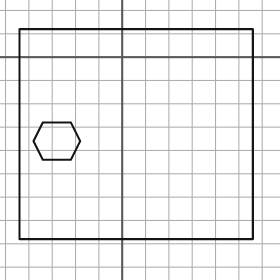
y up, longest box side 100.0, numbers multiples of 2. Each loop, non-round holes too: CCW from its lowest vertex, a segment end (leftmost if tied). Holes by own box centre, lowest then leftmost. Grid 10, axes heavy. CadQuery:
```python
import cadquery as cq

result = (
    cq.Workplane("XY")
    .moveTo(-44.0, -78.0)
    .lineTo(56.0, -78.0)
    .lineTo(56.0, 12.0)
    .lineTo(-44.0, 12.0)
    .close()
    .moveTo(-34.0, -44.0)
    .lineTo(-22.0, -44.0)
    .lineTo(-18.0, -36.0)
    .lineTo(-22.0, -28.0)
    .lineTo(-34.0, -28.0)
    .lineTo(-38.0, -36.0)
    .close()
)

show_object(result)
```